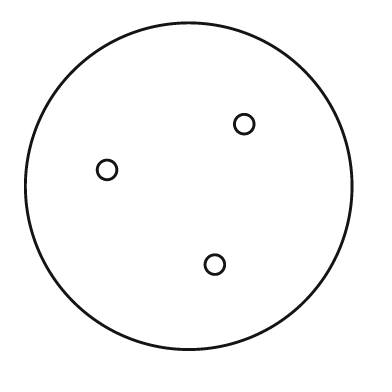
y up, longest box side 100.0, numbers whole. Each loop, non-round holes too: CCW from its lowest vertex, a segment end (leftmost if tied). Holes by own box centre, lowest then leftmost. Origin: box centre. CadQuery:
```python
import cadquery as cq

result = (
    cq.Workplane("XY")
    .moveTo(0.0, 0.0)
    .circle(50.0)
    .moveTo(8.0, -24.0)
    .circle(3.0)
    .moveTo(-25.0, 5.0)
    .circle(3.0)
    .moveTo(17.0, 19.0)
    .circle(3.0)
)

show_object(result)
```